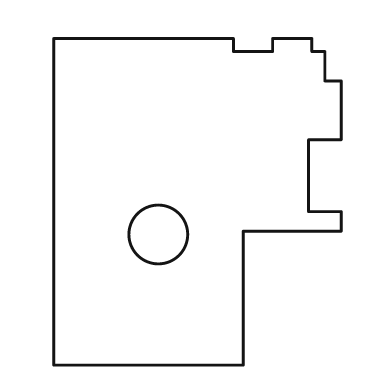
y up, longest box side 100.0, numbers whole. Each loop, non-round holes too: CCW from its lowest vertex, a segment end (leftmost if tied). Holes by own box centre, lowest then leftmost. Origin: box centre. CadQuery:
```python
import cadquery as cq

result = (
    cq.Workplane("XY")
    .moveTo(-44.0, -50.0)
    .lineTo(14.0, -50.0)
    .lineTo(14.0, -9.0)
    .lineTo(44.0, -9.0)
    .lineTo(44.0, -3.0)
    .lineTo(34.0, -3.0)
    .lineTo(34.0, 19.0)
    .lineTo(44.0, 19.0)
    .lineTo(44.0, 37.0)
    .lineTo(39.0, 37.0)
    .lineTo(39.0, 46.0)
    .lineTo(35.0, 46.0)
    .lineTo(35.0, 50.0)
    .lineTo(23.0, 50.0)
    .lineTo(23.0, 46.0)
    .lineTo(11.0, 46.0)
    .lineTo(11.0, 50.0)
    .lineTo(-44.0, 50.0)
    .close()
    .moveTo(-12.0, -10.0)
    .circle(9.0)
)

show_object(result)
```